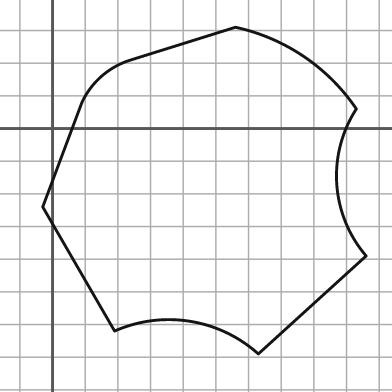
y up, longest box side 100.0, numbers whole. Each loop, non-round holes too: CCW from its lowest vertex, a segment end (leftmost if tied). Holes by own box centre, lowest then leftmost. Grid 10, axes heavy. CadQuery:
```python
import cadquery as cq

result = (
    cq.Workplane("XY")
    .moveTo(63.0, -69.0)
    .lineTo(96.0, -39.0)
    .threePointArc((87.0, -17.0), (93.0, 6.0))
    .threePointArc((77.0, 22.0), (56.0, 31.0))
    .lineTo(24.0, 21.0)
    .threePointArc((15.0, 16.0), (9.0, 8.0))
    .lineTo(-3.0, -24.0)
    .lineTo(19.0, -62.0)
    .threePointArc((42.0, -59.0), (63.0, -69.0))
    .close()
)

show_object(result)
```